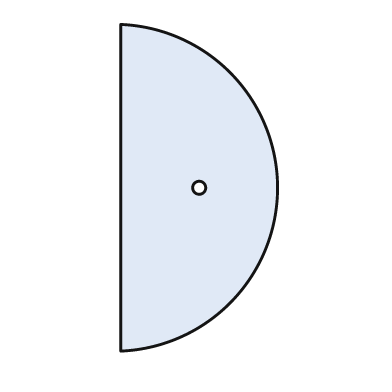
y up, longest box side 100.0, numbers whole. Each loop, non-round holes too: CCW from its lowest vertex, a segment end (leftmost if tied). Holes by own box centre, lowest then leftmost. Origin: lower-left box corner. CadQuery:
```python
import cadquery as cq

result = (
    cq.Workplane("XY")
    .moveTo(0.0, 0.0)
    .threePointArc((48.0, 50.0), (0.0, 100.0))
    .close()
    .moveTo(24.0, 50.0)
    .circle(2.0)
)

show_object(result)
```